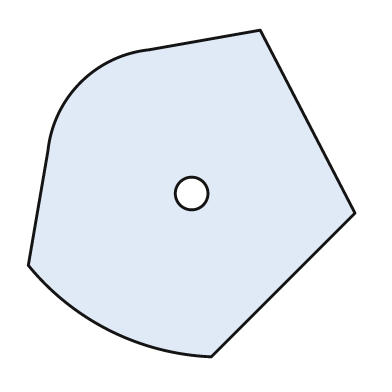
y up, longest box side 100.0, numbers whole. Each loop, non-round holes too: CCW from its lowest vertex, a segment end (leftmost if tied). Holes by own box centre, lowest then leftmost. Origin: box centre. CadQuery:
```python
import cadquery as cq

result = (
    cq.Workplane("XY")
    .moveTo(6.0, -50.0)
    .lineTo(50.0, -6.0)
    .lineTo(21.0, 50.0)
    .lineTo(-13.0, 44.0)
    .threePointArc((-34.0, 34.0), (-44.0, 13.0))
    .lineTo(-50.0, -22.0)
    .threePointArc((-25.0, -42.0), (6.0, -50.0))
    .close()
    .moveTo(0.0, 0.0)
    .circle(5.0)
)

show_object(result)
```